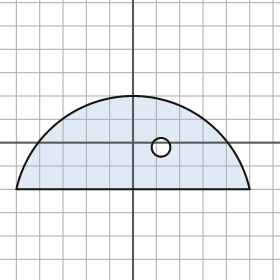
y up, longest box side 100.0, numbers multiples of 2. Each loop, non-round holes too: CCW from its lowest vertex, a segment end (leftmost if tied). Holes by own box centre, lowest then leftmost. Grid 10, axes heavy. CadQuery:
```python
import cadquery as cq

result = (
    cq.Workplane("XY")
    .moveTo(-50.0, -20.0)
    .lineTo(50.0, -20.0)
    .threePointArc((0.0, 20.0), (-50.0, -20.0))
    .close()
    .moveTo(12.0, -2.0)
    .circle(4.0)
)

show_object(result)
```